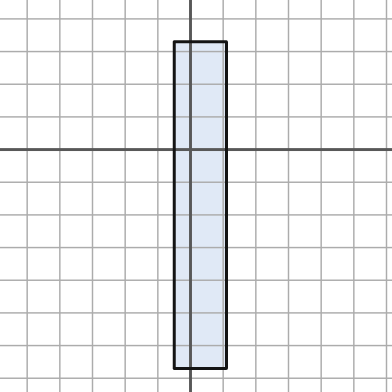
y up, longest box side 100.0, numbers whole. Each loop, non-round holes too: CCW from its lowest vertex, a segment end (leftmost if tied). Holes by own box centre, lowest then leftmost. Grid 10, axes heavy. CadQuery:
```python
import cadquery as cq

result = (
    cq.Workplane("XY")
    .moveTo(-5.0, -67.0)
    .lineTo(11.0, -67.0)
    .lineTo(11.0, 33.0)
    .lineTo(-5.0, 33.0)
    .close()
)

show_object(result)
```